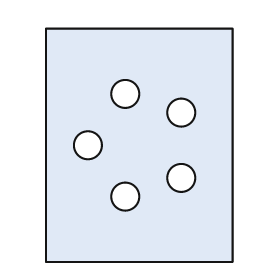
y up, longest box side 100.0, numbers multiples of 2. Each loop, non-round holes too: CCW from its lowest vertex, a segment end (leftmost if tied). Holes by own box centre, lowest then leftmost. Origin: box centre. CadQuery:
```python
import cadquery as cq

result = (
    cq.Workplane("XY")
    .moveTo(-40.0, -50.0)
    .lineTo(40.0, -50.0)
    .lineTo(40.0, 50.0)
    .lineTo(-40.0, 50.0)
    .close()
    .moveTo(-6.0, -22.0)
    .circle(6.0)
    .moveTo(18.0, -14.0)
    .circle(6.0)
    .moveTo(-22.0, 0.0)
    .circle(6.0)
    .moveTo(18.0, 14.0)
    .circle(6.0)
    .moveTo(-6.0, 22.0)
    .circle(6.0)
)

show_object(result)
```